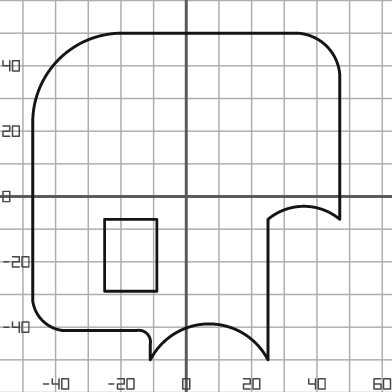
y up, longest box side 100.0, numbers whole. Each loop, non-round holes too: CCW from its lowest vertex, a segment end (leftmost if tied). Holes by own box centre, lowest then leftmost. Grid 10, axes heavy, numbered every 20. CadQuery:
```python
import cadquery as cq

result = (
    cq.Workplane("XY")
    .moveTo(-11.0, -50.0)
    .threePointArc((7.0, -39.0), (25.0, -50.0))
    .lineTo(25.0, -7.0)
    .threePointArc((36.0, -3.0), (47.0, -7.0))
    .lineTo(47.0, 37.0)
    .threePointArc((43.0, 46.0), (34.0, 50.0))
    .lineTo(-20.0, 50.0)
    .threePointArc((-39.0, 42.0), (-47.0, 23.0))
    .lineTo(-47.0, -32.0)
    .threePointArc((-44.0, -38.0), (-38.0, -41.0))
    .lineTo(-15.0, -41.0)
    .threePointArc((-12.0, -42.0), (-11.0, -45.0))
    .close()
    .moveTo(-25.0, -29.0)
    .lineTo(-9.0, -29.0)
    .lineTo(-9.0, -7.0)
    .lineTo(-25.0, -7.0)
    .close()
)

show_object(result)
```